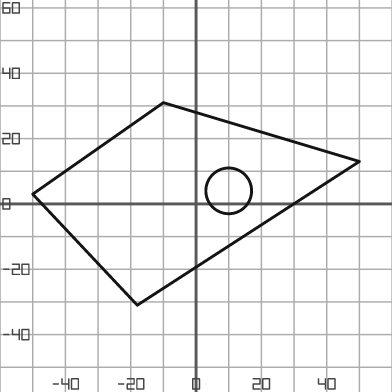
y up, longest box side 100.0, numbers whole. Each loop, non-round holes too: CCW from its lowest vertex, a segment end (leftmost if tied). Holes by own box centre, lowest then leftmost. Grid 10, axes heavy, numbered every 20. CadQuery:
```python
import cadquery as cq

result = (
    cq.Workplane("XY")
    .moveTo(-18.0, -31.0)
    .lineTo(50.0, 13.0)
    .lineTo(-10.0, 31.0)
    .lineTo(-50.0, 3.0)
    .close()
    .moveTo(10.0, 4.0)
    .circle(7.0)
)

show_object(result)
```